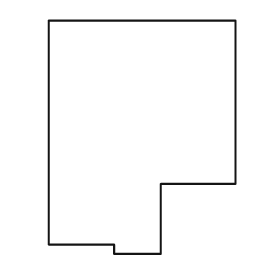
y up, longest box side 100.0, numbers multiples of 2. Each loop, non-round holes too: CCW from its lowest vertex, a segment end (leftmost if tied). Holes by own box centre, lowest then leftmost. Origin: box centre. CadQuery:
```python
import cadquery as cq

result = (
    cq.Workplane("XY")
    .moveTo(-12.0, -50.0)
    .lineTo(8.0, -50.0)
    .lineTo(8.0, -20.0)
    .lineTo(40.0, -20.0)
    .lineTo(40.0, 50.0)
    .lineTo(-40.0, 50.0)
    .lineTo(-40.0, -46.0)
    .lineTo(-12.0, -46.0)
    .close()
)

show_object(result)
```